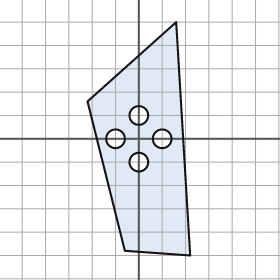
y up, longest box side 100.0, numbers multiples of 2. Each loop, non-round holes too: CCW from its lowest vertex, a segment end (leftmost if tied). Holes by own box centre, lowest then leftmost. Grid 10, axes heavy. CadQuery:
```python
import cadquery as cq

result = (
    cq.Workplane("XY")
    .moveTo(22.0, -50.0)
    .lineTo(16.0, 50.0)
    .lineTo(-22.0, 16.0)
    .lineTo(-6.0, -48.0)
    .close()
    .moveTo(0.0, -10.0)
    .circle(4.0)
    .moveTo(-10.0, 0.0)
    .circle(4.0)
    .moveTo(10.0, 0.0)
    .circle(4.0)
    .moveTo(0.0, 10.0)
    .circle(4.0)
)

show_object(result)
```